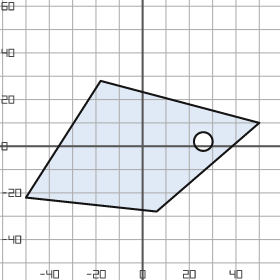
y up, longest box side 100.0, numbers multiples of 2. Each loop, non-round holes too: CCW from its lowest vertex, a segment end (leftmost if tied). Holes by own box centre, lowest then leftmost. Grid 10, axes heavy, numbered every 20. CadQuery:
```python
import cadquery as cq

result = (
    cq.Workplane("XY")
    .moveTo(6.0, -28.0)
    .lineTo(50.0, 10.0)
    .lineTo(-18.0, 28.0)
    .lineTo(-50.0, -22.0)
    .close()
    .moveTo(26.0, 2.0)
    .circle(4.0)
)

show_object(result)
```